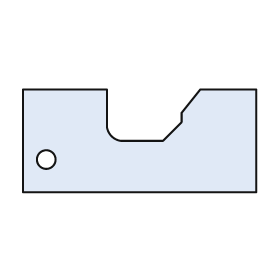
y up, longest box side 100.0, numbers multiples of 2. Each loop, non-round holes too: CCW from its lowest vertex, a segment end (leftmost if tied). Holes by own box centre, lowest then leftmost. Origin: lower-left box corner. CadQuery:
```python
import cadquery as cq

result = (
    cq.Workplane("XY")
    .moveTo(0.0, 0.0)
    .lineTo(100.0, 0.0)
    .lineTo(100.0, 44.0)
    .lineTo(76.0, 44.0)
    .lineTo(68.0, 34.0)
    .lineTo(68.0, 30.0)
    .lineTo(60.0, 22.0)
    .lineTo(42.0, 22.0)
    .threePointArc((38.0, 24.0), (36.0, 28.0))
    .lineTo(36.0, 44.0)
    .lineTo(0.0, 44.0)
    .close()
    .moveTo(10.0, 14.0)
    .circle(4.0)
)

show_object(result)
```